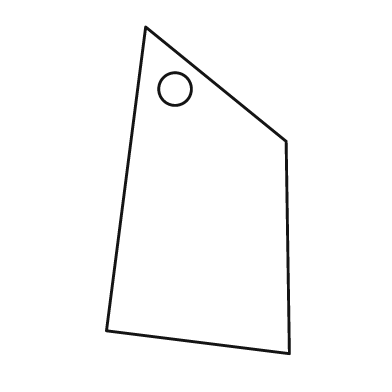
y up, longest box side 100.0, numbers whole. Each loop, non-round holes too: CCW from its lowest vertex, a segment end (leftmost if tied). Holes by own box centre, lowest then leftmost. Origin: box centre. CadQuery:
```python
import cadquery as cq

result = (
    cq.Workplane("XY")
    .moveTo(28.0, -50.0)
    .lineTo(27.0, 15.0)
    .lineTo(-16.0, 50.0)
    .lineTo(-28.0, -43.0)
    .close()
    .moveTo(-7.0, 31.0)
    .circle(5.0)
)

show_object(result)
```